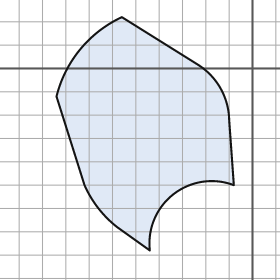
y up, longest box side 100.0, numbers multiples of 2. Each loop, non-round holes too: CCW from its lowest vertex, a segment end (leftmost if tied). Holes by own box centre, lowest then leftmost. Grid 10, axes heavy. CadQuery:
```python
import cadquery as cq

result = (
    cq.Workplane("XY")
    .moveTo(-44.0, -78.0)
    .threePointArc((-34.0, -54.0), (-8.0, -50.0))
    .lineTo(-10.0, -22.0)
    .threePointArc((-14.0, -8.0), (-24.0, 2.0))
    .lineTo(-56.0, 22.0)
    .threePointArc((-74.0, 8.0), (-84.0, -12.0))
    .lineTo(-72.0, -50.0)
    .threePointArc((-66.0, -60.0), (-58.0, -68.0))
    .close()
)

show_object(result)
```